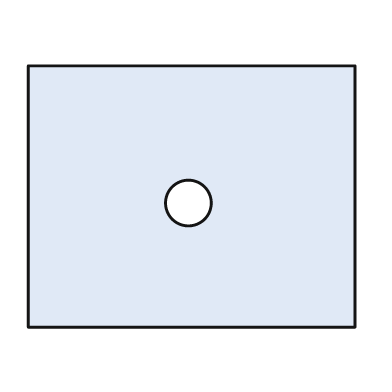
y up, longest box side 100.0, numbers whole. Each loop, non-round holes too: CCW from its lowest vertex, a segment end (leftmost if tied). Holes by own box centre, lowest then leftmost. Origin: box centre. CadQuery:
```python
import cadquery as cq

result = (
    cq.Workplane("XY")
    .moveTo(-50.0, -40.0)
    .lineTo(50.0, -40.0)
    .lineTo(50.0, 40.0)
    .lineTo(-50.0, 40.0)
    .close()
    .moveTo(-1.0, -2.0)
    .circle(7.0)
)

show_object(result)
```